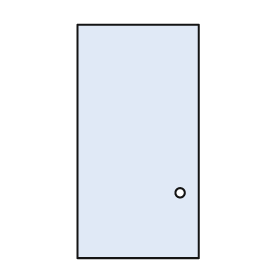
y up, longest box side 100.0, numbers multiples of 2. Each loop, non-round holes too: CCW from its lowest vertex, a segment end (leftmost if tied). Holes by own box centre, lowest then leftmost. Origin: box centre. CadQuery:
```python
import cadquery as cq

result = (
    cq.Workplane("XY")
    .moveTo(-26.0, -50.0)
    .lineTo(26.0, -50.0)
    .lineTo(26.0, 50.0)
    .lineTo(-26.0, 50.0)
    .close()
    .moveTo(18.0, -22.0)
    .circle(2.0)
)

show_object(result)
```